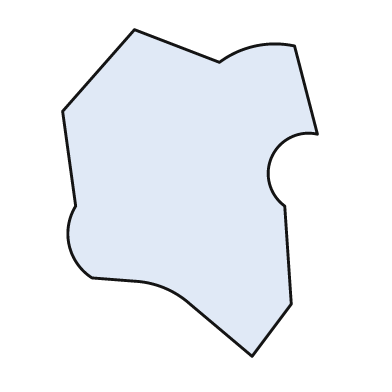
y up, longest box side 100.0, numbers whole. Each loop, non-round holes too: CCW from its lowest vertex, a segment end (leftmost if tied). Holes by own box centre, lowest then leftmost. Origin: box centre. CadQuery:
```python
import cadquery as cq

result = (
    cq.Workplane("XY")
    .moveTo(19.0, -50.0)
    .lineTo(31.0, -34.0)
    .lineTo(29.0, -4.0)
    .threePointArc((25.0, 11.0), (39.0, 18.0))
    .lineTo(32.0, 45.0)
    .threePointArc((20.0, 45.0), (9.0, 40.0))
    .lineTo(-17.0, 50.0)
    .lineTo(-39.0, 25.0)
    .lineTo(-35.0, -4.0)
    .threePointArc((-37.0, -16.0), (-30.0, -26.0))
    .lineTo(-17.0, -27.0)
    .threePointArc((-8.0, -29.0), (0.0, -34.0))
    .close()
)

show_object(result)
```